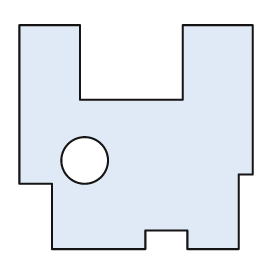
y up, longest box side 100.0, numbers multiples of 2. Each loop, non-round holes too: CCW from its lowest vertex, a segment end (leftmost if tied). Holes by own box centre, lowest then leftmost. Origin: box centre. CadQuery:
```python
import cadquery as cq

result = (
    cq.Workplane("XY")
    .moveTo(-36.0, -48.0)
    .lineTo(4.0, -48.0)
    .lineTo(4.0, -40.0)
    .lineTo(22.0, -40.0)
    .lineTo(22.0, -48.0)
    .lineTo(44.0, -48.0)
    .lineTo(44.0, -16.0)
    .lineTo(50.0, -16.0)
    .lineTo(50.0, 48.0)
    .lineTo(20.0, 48.0)
    .lineTo(20.0, 16.0)
    .lineTo(-24.0, 16.0)
    .lineTo(-24.0, 48.0)
    .lineTo(-50.0, 48.0)
    .lineTo(-50.0, -20.0)
    .lineTo(-36.0, -20.0)
    .close()
    .moveTo(-22.0, -10.0)
    .circle(10.0)
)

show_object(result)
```